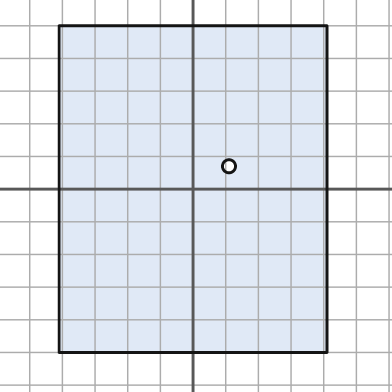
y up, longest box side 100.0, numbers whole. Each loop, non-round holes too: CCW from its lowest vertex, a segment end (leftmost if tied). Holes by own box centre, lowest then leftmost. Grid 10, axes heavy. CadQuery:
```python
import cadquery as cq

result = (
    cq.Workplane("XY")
    .moveTo(-41.0, -50.0)
    .lineTo(41.0, -50.0)
    .lineTo(41.0, 50.0)
    .lineTo(-41.0, 50.0)
    .close()
    .moveTo(11.0, 7.0)
    .circle(2.0)
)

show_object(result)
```